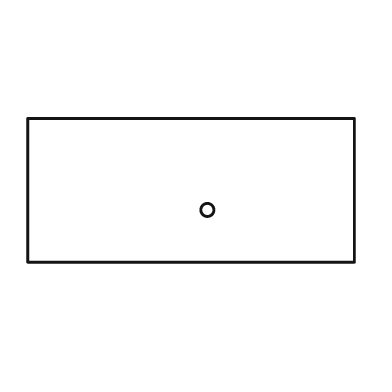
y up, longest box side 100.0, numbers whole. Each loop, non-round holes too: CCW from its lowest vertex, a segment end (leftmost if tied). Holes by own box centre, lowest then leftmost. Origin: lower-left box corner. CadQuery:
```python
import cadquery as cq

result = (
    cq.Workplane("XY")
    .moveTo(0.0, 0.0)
    .lineTo(100.0, 0.0)
    .lineTo(100.0, 44.0)
    .lineTo(0.0, 44.0)
    .close()
    .moveTo(55.0, 16.0)
    .circle(2.0)
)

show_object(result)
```